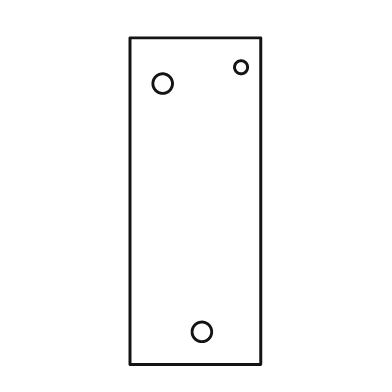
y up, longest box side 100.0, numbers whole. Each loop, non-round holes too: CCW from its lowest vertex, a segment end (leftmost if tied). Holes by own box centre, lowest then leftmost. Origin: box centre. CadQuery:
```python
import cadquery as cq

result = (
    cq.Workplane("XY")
    .moveTo(-20.0, -50.0)
    .lineTo(20.0, -50.0)
    .lineTo(20.0, 50.0)
    .lineTo(-20.0, 50.0)
    .close()
    .moveTo(2.0, -40.0)
    .circle(3.0)
    .moveTo(-10.0, 36.0)
    .circle(3.0)
    .moveTo(14.0, 41.0)
    .circle(2.0)
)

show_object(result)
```